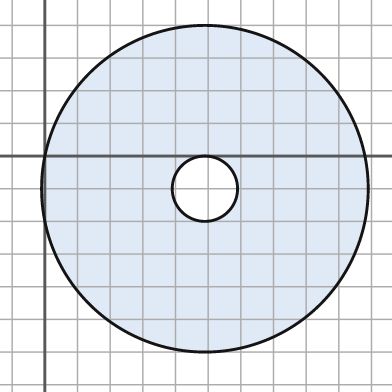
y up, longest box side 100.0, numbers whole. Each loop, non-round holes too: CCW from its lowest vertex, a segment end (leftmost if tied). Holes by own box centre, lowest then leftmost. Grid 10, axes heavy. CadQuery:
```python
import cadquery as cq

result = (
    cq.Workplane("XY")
    .moveTo(49.0, -10.0)
    .circle(50.0)
    .moveTo(49.0, -10.0)
    .circle(10.0)
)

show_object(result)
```